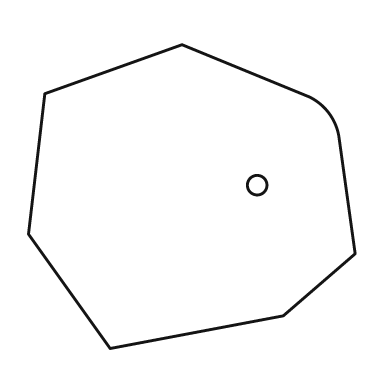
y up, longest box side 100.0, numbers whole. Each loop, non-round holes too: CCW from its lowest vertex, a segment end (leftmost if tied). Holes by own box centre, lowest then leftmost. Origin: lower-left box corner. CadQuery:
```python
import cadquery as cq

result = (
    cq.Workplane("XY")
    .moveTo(25.0, 0.0)
    .lineTo(78.0, 10.0)
    .lineTo(100.0, 29.0)
    .lineTo(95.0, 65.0)
    .threePointArc((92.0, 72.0), (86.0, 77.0))
    .lineTo(47.0, 93.0)
    .lineTo(5.0, 78.0)
    .lineTo(0.0, 35.0)
    .close()
    .moveTo(70.0, 50.0)
    .circle(3.0)
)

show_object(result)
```